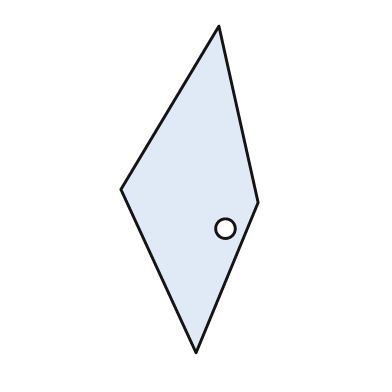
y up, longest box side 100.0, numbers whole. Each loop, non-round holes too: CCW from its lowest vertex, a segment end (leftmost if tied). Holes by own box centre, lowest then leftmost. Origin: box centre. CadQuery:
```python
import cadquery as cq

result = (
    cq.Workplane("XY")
    .moveTo(2.0, -50.0)
    .lineTo(21.0, -4.0)
    .lineTo(9.0, 50.0)
    .lineTo(-21.0, 0.0)
    .close()
    .moveTo(11.0, -12.0)
    .circle(3.0)
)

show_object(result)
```